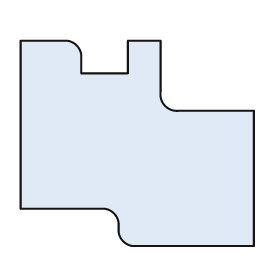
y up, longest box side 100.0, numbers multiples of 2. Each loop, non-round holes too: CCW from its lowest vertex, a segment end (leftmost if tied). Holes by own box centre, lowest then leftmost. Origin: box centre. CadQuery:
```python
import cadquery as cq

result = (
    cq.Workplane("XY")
    .moveTo(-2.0, -44.0)
    .lineTo(50.0, -44.0)
    .lineTo(50.0, 14.0)
    .lineTo(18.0, 14.0)
    .threePointArc((12.0, 16.0), (10.0, 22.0))
    .lineTo(10.0, 44.0)
    .lineTo(-4.0, 44.0)
    .lineTo(-4.0, 30.0)
    .lineTo(-24.0, 30.0)
    .lineTo(-24.0, 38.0)
    .threePointArc((-26.0, 42.0), (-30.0, 44.0))
    .lineTo(-50.0, 44.0)
    .lineTo(-50.0, -28.0)
    .lineTo(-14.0, -28.0)
    .threePointArc((-10.0, -30.0), (-8.0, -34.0))
    .lineTo(-8.0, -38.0)
    .threePointArc((-6.0, -42.0), (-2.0, -44.0))
    .close()
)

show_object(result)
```